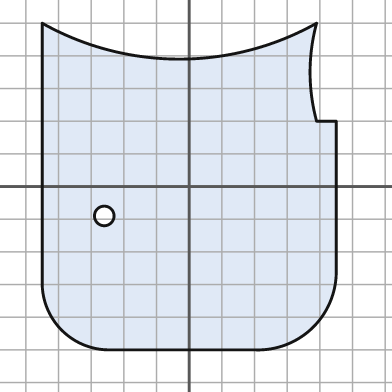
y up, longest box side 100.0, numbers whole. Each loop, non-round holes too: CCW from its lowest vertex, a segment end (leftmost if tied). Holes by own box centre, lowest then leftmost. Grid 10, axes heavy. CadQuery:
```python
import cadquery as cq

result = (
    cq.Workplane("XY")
    .moveTo(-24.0, -50.0)
    .lineTo(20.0, -50.0)
    .threePointArc((38.0, -43.0), (45.0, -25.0))
    .lineTo(45.0, 20.0)
    .lineTo(39.0, 20.0)
    .threePointArc((37.0, 35.0), (39.0, 50.0))
    .threePointArc((-3.0, 39.0), (-45.0, 50.0))
    .lineTo(-45.0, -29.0)
    .threePointArc((-39.0, -44.0), (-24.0, -50.0))
    .close()
    .moveTo(-26.0, -9.0)
    .circle(3.0)
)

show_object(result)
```